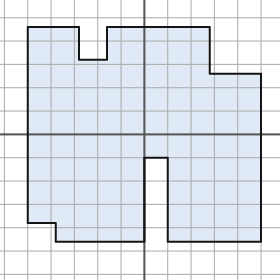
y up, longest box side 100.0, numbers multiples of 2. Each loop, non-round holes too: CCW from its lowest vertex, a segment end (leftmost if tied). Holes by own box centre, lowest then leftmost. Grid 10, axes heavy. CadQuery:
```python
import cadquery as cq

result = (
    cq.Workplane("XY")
    .moveTo(-38.0, -46.0)
    .lineTo(0.0, -46.0)
    .lineTo(0.0, -10.0)
    .lineTo(10.0, -10.0)
    .lineTo(10.0, -46.0)
    .lineTo(50.0, -46.0)
    .lineTo(50.0, 26.0)
    .lineTo(28.0, 26.0)
    .lineTo(28.0, 46.0)
    .lineTo(-16.0, 46.0)
    .lineTo(-16.0, 32.0)
    .lineTo(-28.0, 32.0)
    .lineTo(-28.0, 46.0)
    .lineTo(-50.0, 46.0)
    .lineTo(-50.0, -38.0)
    .lineTo(-38.0, -38.0)
    .close()
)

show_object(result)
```